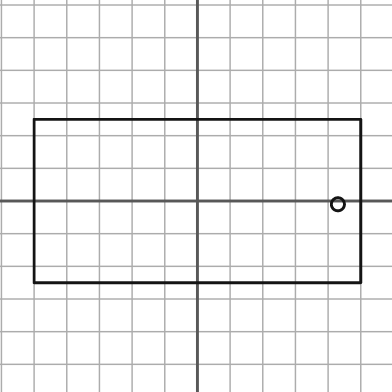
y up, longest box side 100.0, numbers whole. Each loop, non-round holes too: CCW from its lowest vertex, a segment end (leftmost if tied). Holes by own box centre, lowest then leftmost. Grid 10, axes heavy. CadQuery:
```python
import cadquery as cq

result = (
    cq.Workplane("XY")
    .moveTo(-50.0, -25.0)
    .lineTo(50.0, -25.0)
    .lineTo(50.0, 25.0)
    .lineTo(-50.0, 25.0)
    .close()
    .moveTo(43.0, -1.0)
    .circle(2.0)
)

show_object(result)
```